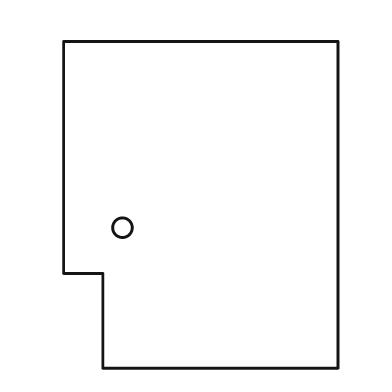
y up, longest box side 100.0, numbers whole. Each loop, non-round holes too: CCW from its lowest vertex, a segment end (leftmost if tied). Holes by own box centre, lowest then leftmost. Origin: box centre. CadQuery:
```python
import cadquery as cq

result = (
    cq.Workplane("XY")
    .moveTo(-30.0, -50.0)
    .lineTo(42.0, -50.0)
    .lineTo(42.0, 50.0)
    .lineTo(-42.0, 50.0)
    .lineTo(-42.0, -21.0)
    .lineTo(-30.0, -21.0)
    .close()
    .moveTo(-24.0, -7.0)
    .circle(3.0)
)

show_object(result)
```